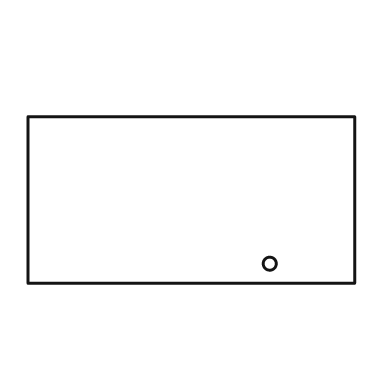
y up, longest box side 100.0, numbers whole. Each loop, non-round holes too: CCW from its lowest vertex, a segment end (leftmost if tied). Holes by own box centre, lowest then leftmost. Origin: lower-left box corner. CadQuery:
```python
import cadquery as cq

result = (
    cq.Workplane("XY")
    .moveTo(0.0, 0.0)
    .lineTo(100.0, 0.0)
    .lineTo(100.0, 51.0)
    .lineTo(0.0, 51.0)
    .close()
    .moveTo(74.0, 6.0)
    .circle(2.0)
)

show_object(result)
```